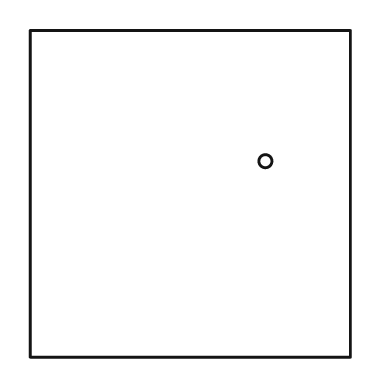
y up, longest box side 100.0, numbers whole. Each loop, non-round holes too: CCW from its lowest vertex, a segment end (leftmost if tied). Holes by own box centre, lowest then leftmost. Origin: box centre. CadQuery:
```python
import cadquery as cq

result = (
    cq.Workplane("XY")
    .moveTo(-49.0, -50.0)
    .lineTo(49.0, -50.0)
    .lineTo(49.0, 50.0)
    .lineTo(-49.0, 50.0)
    .close()
    .moveTo(23.0, 10.0)
    .circle(2.0)
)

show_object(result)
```